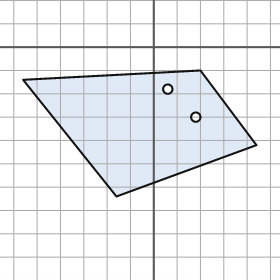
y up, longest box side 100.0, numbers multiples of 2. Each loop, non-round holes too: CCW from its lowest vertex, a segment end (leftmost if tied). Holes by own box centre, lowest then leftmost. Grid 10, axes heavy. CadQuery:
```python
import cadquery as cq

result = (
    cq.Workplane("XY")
    .moveTo(-16.0, -64.0)
    .lineTo(44.0, -42.0)
    .lineTo(20.0, -10.0)
    .lineTo(-56.0, -14.0)
    .close()
    .moveTo(18.0, -30.0)
    .circle(2.0)
    .moveTo(6.0, -18.0)
    .circle(2.0)
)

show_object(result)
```